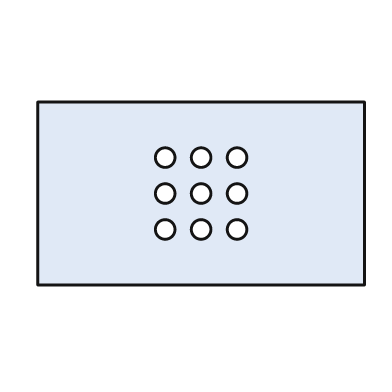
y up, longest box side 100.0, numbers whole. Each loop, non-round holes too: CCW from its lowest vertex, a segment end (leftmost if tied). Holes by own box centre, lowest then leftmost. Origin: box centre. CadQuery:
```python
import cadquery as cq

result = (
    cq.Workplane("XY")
    .moveTo(-50.0, -28.0)
    .lineTo(50.0, -28.0)
    .lineTo(50.0, 28.0)
    .lineTo(-50.0, 28.0)
    .close()
    .moveTo(-11.0, -11.0)
    .circle(3.0)
    .moveTo(0.0, -11.0)
    .circle(3.0)
    .moveTo(11.0, -11.0)
    .circle(3.0)
    .moveTo(-11.0, 0.0)
    .circle(3.0)
    .moveTo(0.0, 0.0)
    .circle(3.0)
    .moveTo(11.0, 0.0)
    .circle(3.0)
    .moveTo(-11.0, 11.0)
    .circle(3.0)
    .moveTo(0.0, 11.0)
    .circle(3.0)
    .moveTo(11.0, 11.0)
    .circle(3.0)
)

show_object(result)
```